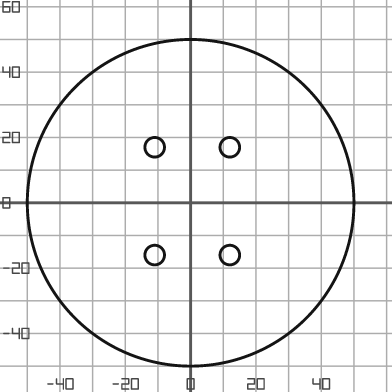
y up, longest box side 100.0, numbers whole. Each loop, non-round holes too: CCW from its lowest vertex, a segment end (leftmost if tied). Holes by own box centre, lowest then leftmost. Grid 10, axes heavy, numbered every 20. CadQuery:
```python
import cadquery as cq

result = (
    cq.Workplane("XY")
    .moveTo(0.0, 0.0)
    .circle(50.0)
    .moveTo(-11.0, -16.0)
    .circle(3.0)
    .moveTo(12.0, -16.0)
    .circle(3.0)
    .moveTo(-11.0, 17.0)
    .circle(3.0)
    .moveTo(12.0, 17.0)
    .circle(3.0)
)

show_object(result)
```